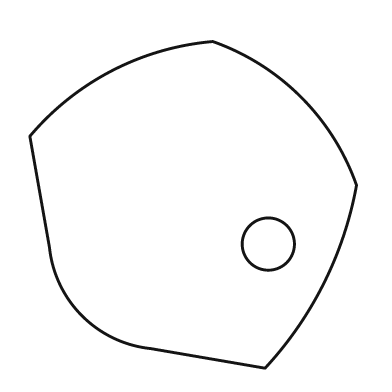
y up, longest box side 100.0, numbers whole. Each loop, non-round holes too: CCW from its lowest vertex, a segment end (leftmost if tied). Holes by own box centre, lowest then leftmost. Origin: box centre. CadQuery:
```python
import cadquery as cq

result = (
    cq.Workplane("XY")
    .moveTo(22.0, -50.0)
    .threePointArc((40.0, -24.0), (50.0, 6.0))
    .threePointArc((33.0, 33.0), (6.0, 50.0))
    .threePointArc((-25.0, 41.0), (-50.0, 21.0))
    .lineTo(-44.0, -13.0)
    .threePointArc((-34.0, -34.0), (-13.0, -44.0))
    .close()
    .moveTo(23.0, -12.0)
    .circle(8.0)
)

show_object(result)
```